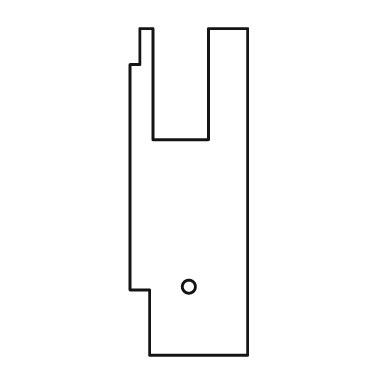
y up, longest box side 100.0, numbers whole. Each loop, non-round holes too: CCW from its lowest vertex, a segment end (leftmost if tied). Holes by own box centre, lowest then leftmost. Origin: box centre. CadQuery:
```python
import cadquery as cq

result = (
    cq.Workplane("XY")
    .moveTo(-12.0, -50.0)
    .lineTo(18.0, -50.0)
    .lineTo(18.0, 50.0)
    .lineTo(6.0, 50.0)
    .lineTo(6.0, 16.0)
    .lineTo(-11.0, 16.0)
    .lineTo(-11.0, 50.0)
    .lineTo(-15.0, 50.0)
    .lineTo(-15.0, 39.0)
    .lineTo(-18.0, 39.0)
    .lineTo(-18.0, -30.0)
    .lineTo(-12.0, -30.0)
    .close()
    .moveTo(0.0, -29.0)
    .circle(2.0)
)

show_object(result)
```